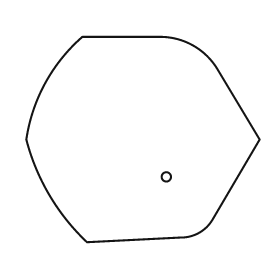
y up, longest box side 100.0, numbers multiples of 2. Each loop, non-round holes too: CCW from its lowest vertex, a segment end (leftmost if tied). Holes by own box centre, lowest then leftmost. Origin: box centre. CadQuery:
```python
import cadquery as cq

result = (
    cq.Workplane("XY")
    .moveTo(-24.0, -44.0)
    .lineTo(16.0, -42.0)
    .threePointArc((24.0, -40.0), (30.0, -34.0))
    .lineTo(50.0, 0.0)
    .lineTo(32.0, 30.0)
    .threePointArc((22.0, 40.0), (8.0, 44.0))
    .lineTo(-26.0, 44.0)
    .threePointArc((-42.0, 24.0), (-50.0, 0.0))
    .threePointArc((-40.0, -24.0), (-24.0, -44.0))
    .close()
    .moveTo(10.0, -16.0)
    .circle(2.0)
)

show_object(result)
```